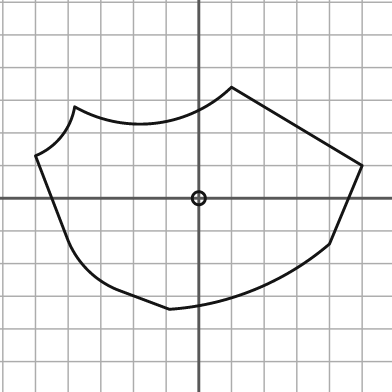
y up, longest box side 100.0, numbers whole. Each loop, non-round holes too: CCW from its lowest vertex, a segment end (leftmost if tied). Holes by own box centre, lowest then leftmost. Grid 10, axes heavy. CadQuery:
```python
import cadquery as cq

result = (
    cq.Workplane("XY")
    .moveTo(-9.0, -34.0)
    .threePointArc((17.0, -28.0), (40.0, -14.0))
    .lineTo(50.0, 10.0)
    .lineTo(10.0, 34.0)
    .threePointArc((-13.0, 23.0), (-38.0, 28.0))
    .threePointArc((-42.0, 19.0), (-50.0, 13.0))
    .lineTo(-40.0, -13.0)
    .threePointArc((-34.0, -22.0), (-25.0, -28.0))
    .close()
    .moveTo(0.0, 0.0)
    .circle(2.0)
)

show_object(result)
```